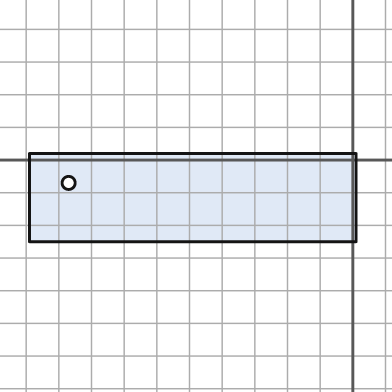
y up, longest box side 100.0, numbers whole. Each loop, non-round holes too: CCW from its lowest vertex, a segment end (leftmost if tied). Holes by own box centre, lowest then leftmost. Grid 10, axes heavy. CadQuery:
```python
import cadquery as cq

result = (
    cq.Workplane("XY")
    .moveTo(-99.0, -25.0)
    .lineTo(1.0, -25.0)
    .lineTo(1.0, 2.0)
    .lineTo(-99.0, 2.0)
    .close()
    .moveTo(-87.0, -7.0)
    .circle(2.0)
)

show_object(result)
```